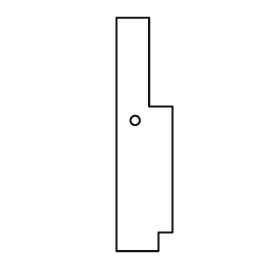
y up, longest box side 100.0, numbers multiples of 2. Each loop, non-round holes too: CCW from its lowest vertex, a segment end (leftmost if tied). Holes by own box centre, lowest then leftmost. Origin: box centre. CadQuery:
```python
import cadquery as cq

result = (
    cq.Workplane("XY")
    .moveTo(-12.0, -50.0)
    .lineTo(6.0, -50.0)
    .lineTo(6.0, -42.0)
    .lineTo(12.0, -42.0)
    .lineTo(12.0, 12.0)
    .lineTo(2.0, 12.0)
    .lineTo(2.0, 50.0)
    .lineTo(-12.0, 50.0)
    .close()
    .moveTo(-4.0, 6.0)
    .circle(2.0)
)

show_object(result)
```